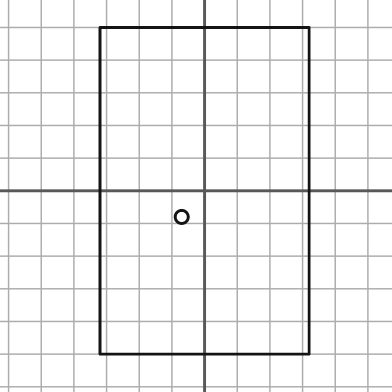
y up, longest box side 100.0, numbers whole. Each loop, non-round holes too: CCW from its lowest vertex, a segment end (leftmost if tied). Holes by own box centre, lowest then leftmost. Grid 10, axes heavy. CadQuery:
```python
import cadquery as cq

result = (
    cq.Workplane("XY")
    .moveTo(-32.0, -50.0)
    .lineTo(32.0, -50.0)
    .lineTo(32.0, 50.0)
    .lineTo(-32.0, 50.0)
    .close()
    .moveTo(-7.0, -8.0)
    .circle(2.0)
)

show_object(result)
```